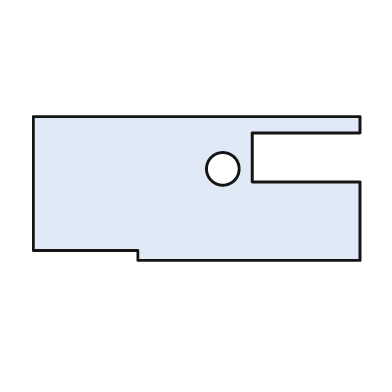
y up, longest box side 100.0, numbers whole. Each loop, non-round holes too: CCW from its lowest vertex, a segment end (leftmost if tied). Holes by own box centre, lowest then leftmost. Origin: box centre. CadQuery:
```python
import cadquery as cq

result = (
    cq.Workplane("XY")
    .moveTo(-18.0, -22.0)
    .lineTo(50.0, -22.0)
    .lineTo(50.0, 2.0)
    .lineTo(17.0, 2.0)
    .lineTo(17.0, 17.0)
    .lineTo(50.0, 17.0)
    .lineTo(50.0, 22.0)
    .lineTo(-50.0, 22.0)
    .lineTo(-50.0, -19.0)
    .lineTo(-18.0, -19.0)
    .close()
    .moveTo(8.0, 6.0)
    .circle(5.0)
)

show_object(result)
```